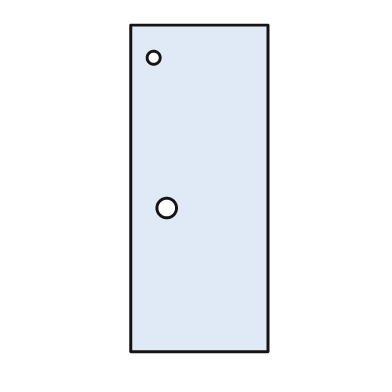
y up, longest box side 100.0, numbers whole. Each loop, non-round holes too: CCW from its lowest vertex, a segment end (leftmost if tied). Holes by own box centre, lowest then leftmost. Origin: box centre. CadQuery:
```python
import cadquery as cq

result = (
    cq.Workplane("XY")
    .moveTo(-21.0, -50.0)
    .lineTo(21.0, -50.0)
    .lineTo(21.0, 50.0)
    .lineTo(-21.0, 50.0)
    .close()
    .moveTo(-10.0, -6.0)
    .circle(3.0)
    .moveTo(-14.0, 40.0)
    .circle(2.0)
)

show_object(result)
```